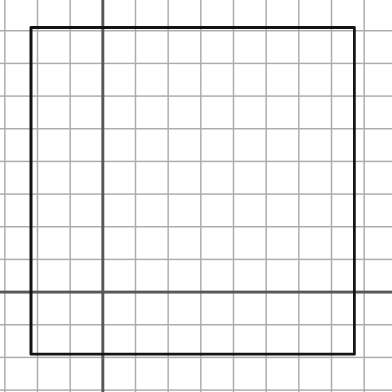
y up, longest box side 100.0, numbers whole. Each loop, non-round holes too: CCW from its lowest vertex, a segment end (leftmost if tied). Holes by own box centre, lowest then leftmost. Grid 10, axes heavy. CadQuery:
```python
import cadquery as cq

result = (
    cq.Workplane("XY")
    .moveTo(-22.0, -19.0)
    .lineTo(77.0, -19.0)
    .lineTo(77.0, 81.0)
    .lineTo(-22.0, 81.0)
    .close()
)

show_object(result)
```